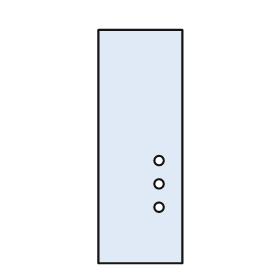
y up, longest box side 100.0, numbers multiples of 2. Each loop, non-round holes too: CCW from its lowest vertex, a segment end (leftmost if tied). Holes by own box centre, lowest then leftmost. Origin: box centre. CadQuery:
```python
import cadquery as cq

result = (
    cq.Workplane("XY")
    .moveTo(-18.0, -50.0)
    .lineTo(18.0, -50.0)
    .lineTo(18.0, 50.0)
    .lineTo(-18.0, 50.0)
    .close()
    .moveTo(8.0, -26.0)
    .circle(2.0)
    .moveTo(8.0, -16.0)
    .circle(2.0)
    .moveTo(8.0, -6.0)
    .circle(2.0)
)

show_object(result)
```